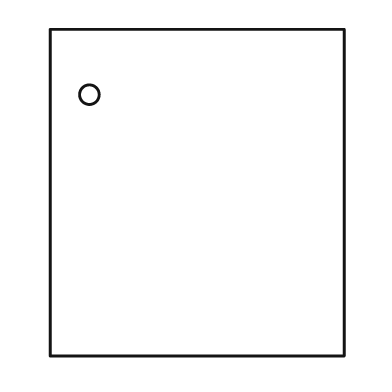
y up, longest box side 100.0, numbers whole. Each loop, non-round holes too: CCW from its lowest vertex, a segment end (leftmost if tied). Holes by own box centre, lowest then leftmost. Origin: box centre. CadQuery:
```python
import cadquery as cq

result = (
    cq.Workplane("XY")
    .moveTo(-45.0, -50.0)
    .lineTo(45.0, -50.0)
    .lineTo(45.0, 50.0)
    .lineTo(-45.0, 50.0)
    .close()
    .moveTo(-33.0, 30.0)
    .circle(3.0)
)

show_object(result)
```